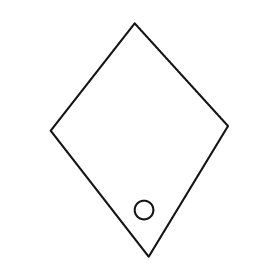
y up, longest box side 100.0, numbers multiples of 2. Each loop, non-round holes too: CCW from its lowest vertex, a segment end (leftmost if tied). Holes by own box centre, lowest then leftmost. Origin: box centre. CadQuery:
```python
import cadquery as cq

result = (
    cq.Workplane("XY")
    .moveTo(4.0, -50.0)
    .lineTo(38.0, 6.0)
    .lineTo(-2.0, 50.0)
    .lineTo(-38.0, 4.0)
    .close()
    .moveTo(2.0, -30.0)
    .circle(4.0)
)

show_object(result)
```